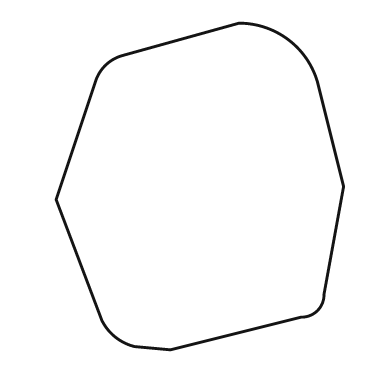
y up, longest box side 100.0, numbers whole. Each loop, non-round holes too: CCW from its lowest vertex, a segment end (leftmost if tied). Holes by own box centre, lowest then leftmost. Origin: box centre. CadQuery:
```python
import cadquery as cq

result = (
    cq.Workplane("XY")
    .moveTo(-9.0, -50.0)
    .lineTo(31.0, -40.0)
    .threePointArc((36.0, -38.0), (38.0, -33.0))
    .lineTo(44.0, 0.0)
    .lineTo(36.0, 32.0)
    .threePointArc((27.0, 45.0), (12.0, 50.0))
    .lineTo(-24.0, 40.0)
    .threePointArc((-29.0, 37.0), (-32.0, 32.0))
    .lineTo(-44.0, -4.0)
    .lineTo(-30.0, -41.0)
    .threePointArc((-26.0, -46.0), (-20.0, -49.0))
    .close()
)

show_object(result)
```